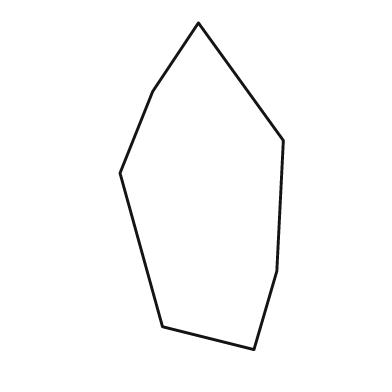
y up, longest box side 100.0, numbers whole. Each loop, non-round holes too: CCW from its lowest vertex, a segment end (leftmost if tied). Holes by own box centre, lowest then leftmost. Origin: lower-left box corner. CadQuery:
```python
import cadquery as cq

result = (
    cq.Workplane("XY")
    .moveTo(41.0, 0.0)
    .lineTo(48.0, 24.0)
    .lineTo(50.0, 64.0)
    .lineTo(24.0, 100.0)
    .lineTo(10.0, 79.0)
    .lineTo(0.0, 54.0)
    .lineTo(13.0, 7.0)
    .close()
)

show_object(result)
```